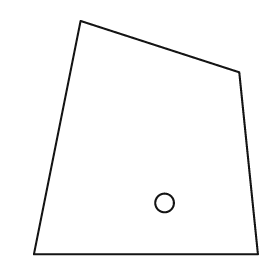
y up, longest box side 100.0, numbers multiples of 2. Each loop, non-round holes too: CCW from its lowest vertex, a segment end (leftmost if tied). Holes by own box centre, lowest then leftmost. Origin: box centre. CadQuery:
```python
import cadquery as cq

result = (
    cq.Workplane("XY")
    .moveTo(-48.0, -50.0)
    .lineTo(48.0, -50.0)
    .lineTo(40.0, 28.0)
    .lineTo(-28.0, 50.0)
    .close()
    .moveTo(8.0, -28.0)
    .circle(4.0)
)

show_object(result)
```